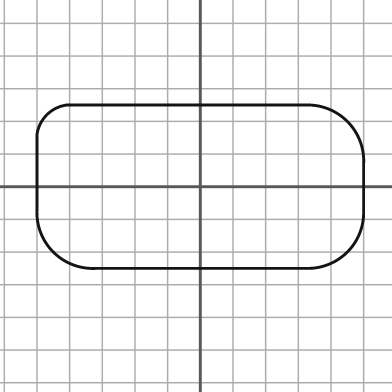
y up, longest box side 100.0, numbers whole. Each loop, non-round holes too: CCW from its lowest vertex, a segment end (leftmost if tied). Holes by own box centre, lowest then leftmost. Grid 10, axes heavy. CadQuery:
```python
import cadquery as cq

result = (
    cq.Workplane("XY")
    .moveTo(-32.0, -25.0)
    .lineTo(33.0, -25.0)
    .threePointArc((45.0, -20.0), (50.0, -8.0))
    .lineTo(50.0, 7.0)
    .threePointArc((45.0, 20.0), (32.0, 25.0))
    .lineTo(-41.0, 25.0)
    .threePointArc((-47.0, 22.0), (-50.0, 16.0))
    .lineTo(-50.0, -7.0)
    .threePointArc((-45.0, -20.0), (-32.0, -25.0))
    .close()
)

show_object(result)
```